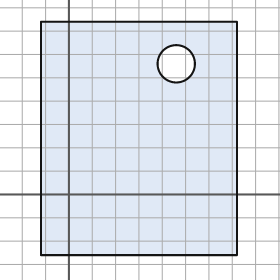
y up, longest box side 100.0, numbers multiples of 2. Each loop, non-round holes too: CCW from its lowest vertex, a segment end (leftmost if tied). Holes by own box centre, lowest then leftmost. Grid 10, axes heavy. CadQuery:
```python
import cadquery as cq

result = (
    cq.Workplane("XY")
    .moveTo(-12.0, -26.0)
    .lineTo(72.0, -26.0)
    .lineTo(72.0, 74.0)
    .lineTo(-12.0, 74.0)
    .close()
    .moveTo(46.0, 56.0)
    .circle(8.0)
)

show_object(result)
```